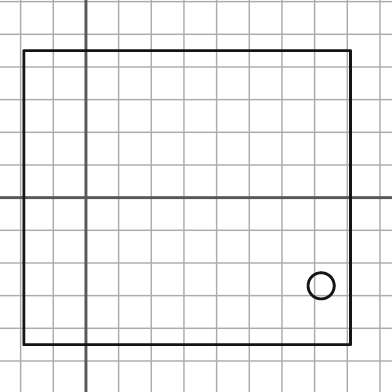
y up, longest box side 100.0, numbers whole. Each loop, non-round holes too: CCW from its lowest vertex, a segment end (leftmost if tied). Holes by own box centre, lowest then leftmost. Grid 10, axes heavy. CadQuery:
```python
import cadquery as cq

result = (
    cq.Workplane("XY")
    .moveTo(-19.0, -45.0)
    .lineTo(81.0, -45.0)
    .lineTo(81.0, 45.0)
    .lineTo(-19.0, 45.0)
    .close()
    .moveTo(72.0, -27.0)
    .circle(4.0)
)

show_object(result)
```